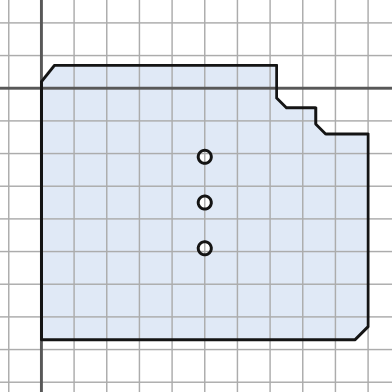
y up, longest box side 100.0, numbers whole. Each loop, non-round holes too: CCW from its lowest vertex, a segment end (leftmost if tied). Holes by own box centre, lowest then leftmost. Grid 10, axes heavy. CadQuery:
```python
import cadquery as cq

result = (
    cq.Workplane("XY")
    .moveTo(0.0, -77.0)
    .lineTo(96.0, -77.0)
    .lineTo(100.0, -73.0)
    .lineTo(100.0, -14.0)
    .lineTo(87.0, -14.0)
    .lineTo(84.0, -11.0)
    .lineTo(84.0, -6.0)
    .lineTo(75.0, -6.0)
    .lineTo(72.0, -3.0)
    .lineTo(72.0, 7.0)
    .lineTo(4.0, 7.0)
    .lineTo(0.0, 2.0)
    .close()
    .moveTo(50.0, -49.0)
    .circle(2.0)
    .moveTo(50.0, -35.0)
    .circle(2.0)
    .moveTo(50.0, -21.0)
    .circle(2.0)
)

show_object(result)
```